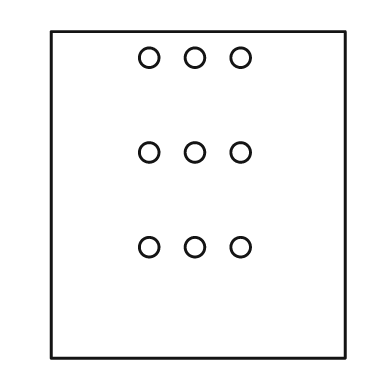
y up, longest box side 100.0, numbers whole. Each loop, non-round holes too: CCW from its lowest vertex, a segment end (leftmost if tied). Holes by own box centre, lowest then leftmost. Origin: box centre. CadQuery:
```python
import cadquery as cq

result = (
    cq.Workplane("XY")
    .moveTo(-45.0, -50.0)
    .lineTo(45.0, -50.0)
    .lineTo(45.0, 50.0)
    .lineTo(-45.0, 50.0)
    .close()
    .moveTo(-15.0, -16.0)
    .circle(3.0)
    .moveTo(-1.0, -16.0)
    .circle(3.0)
    .moveTo(13.0, -16.0)
    .circle(3.0)
    .moveTo(-15.0, 13.0)
    .circle(3.0)
    .moveTo(-1.0, 13.0)
    .circle(3.0)
    .moveTo(13.0, 13.0)
    .circle(3.0)
    .moveTo(-15.0, 42.0)
    .circle(3.0)
    .moveTo(-1.0, 42.0)
    .circle(3.0)
    .moveTo(13.0, 42.0)
    .circle(3.0)
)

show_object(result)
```